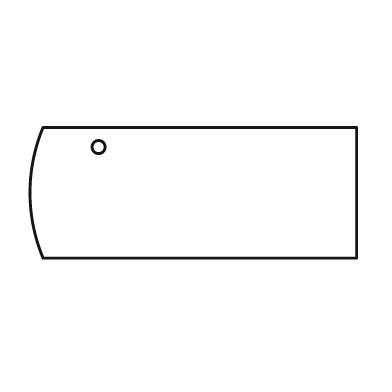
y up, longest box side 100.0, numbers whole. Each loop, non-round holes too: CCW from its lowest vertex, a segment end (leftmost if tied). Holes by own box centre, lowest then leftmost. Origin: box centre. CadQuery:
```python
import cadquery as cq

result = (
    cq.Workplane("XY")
    .moveTo(-46.0, -20.0)
    .lineTo(50.0, -20.0)
    .lineTo(50.0, 20.0)
    .lineTo(-46.0, 20.0)
    .threePointArc((-50.0, 0.0), (-46.0, -20.0))
    .close()
    .moveTo(-29.0, 14.0)
    .circle(2.0)
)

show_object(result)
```